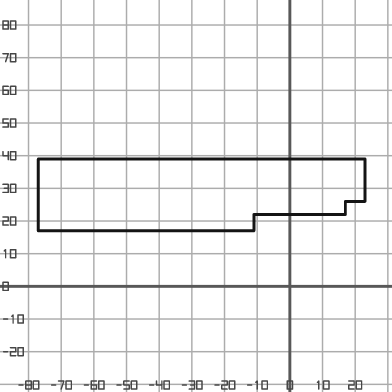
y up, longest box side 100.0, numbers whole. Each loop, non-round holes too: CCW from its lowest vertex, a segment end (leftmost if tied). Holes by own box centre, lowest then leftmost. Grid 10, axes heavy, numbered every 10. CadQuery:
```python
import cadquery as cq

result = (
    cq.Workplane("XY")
    .moveTo(-77.0, 17.0)
    .lineTo(-11.0, 17.0)
    .lineTo(-11.0, 22.0)
    .lineTo(17.0, 22.0)
    .lineTo(17.0, 26.0)
    .lineTo(23.0, 26.0)
    .lineTo(23.0, 39.0)
    .lineTo(-77.0, 39.0)
    .close()
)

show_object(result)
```